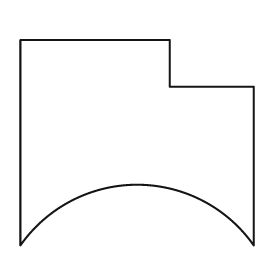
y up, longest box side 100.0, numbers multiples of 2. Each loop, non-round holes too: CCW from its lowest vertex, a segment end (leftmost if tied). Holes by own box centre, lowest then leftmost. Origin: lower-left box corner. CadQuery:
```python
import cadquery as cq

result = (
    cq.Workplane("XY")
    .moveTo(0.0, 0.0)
    .threePointArc((50.0, 26.0), (100.0, 0.0))
    .lineTo(100.0, 68.0)
    .lineTo(64.0, 68.0)
    .lineTo(64.0, 88.0)
    .lineTo(0.0, 88.0)
    .close()
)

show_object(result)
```